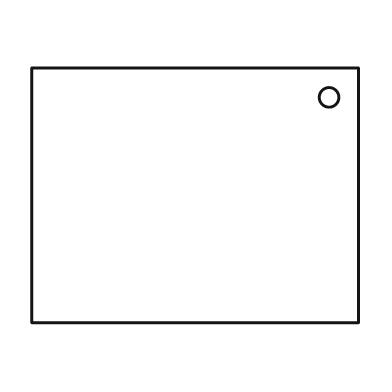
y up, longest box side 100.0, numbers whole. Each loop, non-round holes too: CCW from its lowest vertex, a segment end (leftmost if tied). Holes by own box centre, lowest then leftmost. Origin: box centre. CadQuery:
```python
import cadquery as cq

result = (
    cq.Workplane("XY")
    .moveTo(-50.0, -39.0)
    .lineTo(50.0, -39.0)
    .lineTo(50.0, 39.0)
    .lineTo(-50.0, 39.0)
    .close()
    .moveTo(41.0, 30.0)
    .circle(3.0)
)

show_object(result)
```